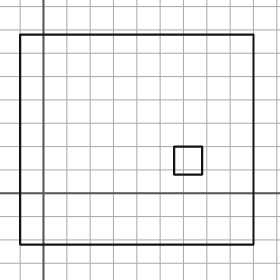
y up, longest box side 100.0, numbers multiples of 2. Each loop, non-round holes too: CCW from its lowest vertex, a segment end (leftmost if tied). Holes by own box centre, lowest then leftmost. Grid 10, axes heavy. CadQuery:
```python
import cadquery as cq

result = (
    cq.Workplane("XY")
    .moveTo(-10.0, -22.0)
    .lineTo(90.0, -22.0)
    .lineTo(90.0, 68.0)
    .lineTo(-10.0, 68.0)
    .close()
    .moveTo(56.0, 8.0)
    .lineTo(68.0, 8.0)
    .lineTo(68.0, 20.0)
    .lineTo(56.0, 20.0)
    .close()
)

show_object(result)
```